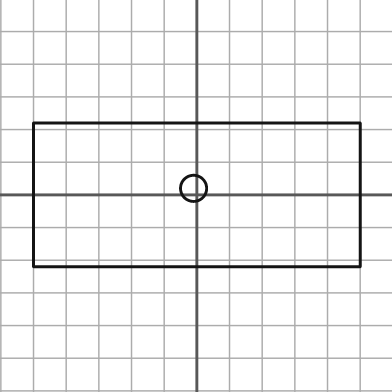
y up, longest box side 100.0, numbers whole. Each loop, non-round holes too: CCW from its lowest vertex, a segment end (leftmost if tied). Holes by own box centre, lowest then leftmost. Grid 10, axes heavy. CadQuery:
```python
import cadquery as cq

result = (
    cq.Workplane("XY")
    .moveTo(-50.0, -22.0)
    .lineTo(50.0, -22.0)
    .lineTo(50.0, 22.0)
    .lineTo(-50.0, 22.0)
    .close()
    .moveTo(-1.0, 2.0)
    .circle(4.0)
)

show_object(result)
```